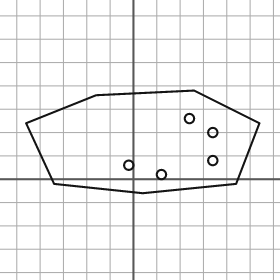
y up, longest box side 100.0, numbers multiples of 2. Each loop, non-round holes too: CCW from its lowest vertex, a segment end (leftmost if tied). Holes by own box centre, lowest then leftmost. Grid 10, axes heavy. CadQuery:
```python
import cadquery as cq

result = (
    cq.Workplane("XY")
    .moveTo(4.0, -6.0)
    .lineTo(44.0, -2.0)
    .lineTo(54.0, 24.0)
    .lineTo(26.0, 38.0)
    .lineTo(-16.0, 36.0)
    .lineTo(-46.0, 24.0)
    .lineTo(-34.0, -2.0)
    .close()
    .moveTo(12.0, 2.0)
    .circle(2.0)
    .moveTo(-2.0, 6.0)
    .circle(2.0)
    .moveTo(34.0, 8.0)
    .circle(2.0)
    .moveTo(34.0, 20.0)
    .circle(2.0)
    .moveTo(24.0, 26.0)
    .circle(2.0)
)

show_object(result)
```